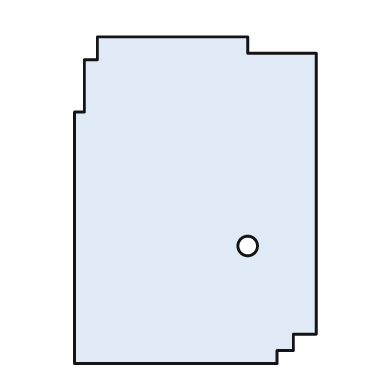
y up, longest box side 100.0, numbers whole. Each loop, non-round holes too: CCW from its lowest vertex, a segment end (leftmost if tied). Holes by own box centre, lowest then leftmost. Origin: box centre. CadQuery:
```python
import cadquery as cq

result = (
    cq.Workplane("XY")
    .moveTo(-37.0, -50.0)
    .lineTo(25.0, -50.0)
    .lineTo(25.0, -46.0)
    .lineTo(30.0, -46.0)
    .lineTo(30.0, -41.0)
    .lineTo(37.0, -41.0)
    .lineTo(37.0, 45.0)
    .lineTo(16.0, 45.0)
    .lineTo(16.0, 50.0)
    .lineTo(-30.0, 50.0)
    .lineTo(-30.0, 43.0)
    .lineTo(-34.0, 43.0)
    .lineTo(-34.0, 27.0)
    .lineTo(-37.0, 27.0)
    .close()
    .moveTo(16.0, -14.0)
    .circle(3.0)
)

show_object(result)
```